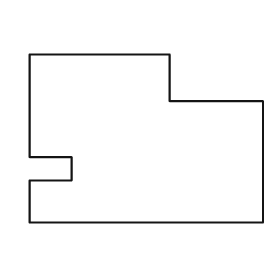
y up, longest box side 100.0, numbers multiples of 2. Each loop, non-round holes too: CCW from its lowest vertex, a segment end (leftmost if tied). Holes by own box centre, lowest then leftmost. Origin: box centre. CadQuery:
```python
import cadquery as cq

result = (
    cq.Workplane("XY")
    .moveTo(-50.0, -36.0)
    .lineTo(50.0, -36.0)
    .lineTo(50.0, 16.0)
    .lineTo(10.0, 16.0)
    .lineTo(10.0, 36.0)
    .lineTo(-50.0, 36.0)
    .lineTo(-50.0, -8.0)
    .lineTo(-32.0, -8.0)
    .lineTo(-32.0, -18.0)
    .lineTo(-50.0, -18.0)
    .close()
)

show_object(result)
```